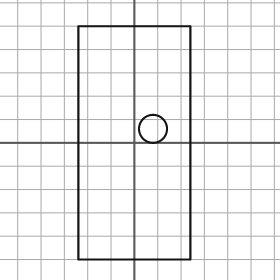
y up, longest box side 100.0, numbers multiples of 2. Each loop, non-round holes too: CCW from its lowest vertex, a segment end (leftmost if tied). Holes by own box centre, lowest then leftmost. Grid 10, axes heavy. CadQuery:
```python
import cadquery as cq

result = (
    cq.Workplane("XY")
    .moveTo(-24.0, -50.0)
    .lineTo(24.0, -50.0)
    .lineTo(24.0, 50.0)
    .lineTo(-24.0, 50.0)
    .close()
    .moveTo(8.0, 6.0)
    .circle(6.0)
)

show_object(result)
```